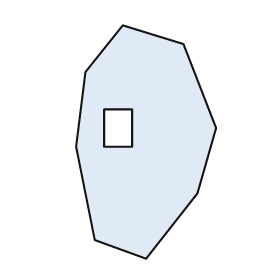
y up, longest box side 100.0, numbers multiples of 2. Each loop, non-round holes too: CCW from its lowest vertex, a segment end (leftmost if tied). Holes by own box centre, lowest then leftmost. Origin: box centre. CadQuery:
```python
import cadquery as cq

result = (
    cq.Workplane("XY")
    .moveTo(0.0, -50.0)
    .lineTo(22.0, -22.0)
    .lineTo(30.0, 6.0)
    .lineTo(16.0, 42.0)
    .lineTo(-10.0, 50.0)
    .lineTo(-26.0, 30.0)
    .lineTo(-30.0, -2.0)
    .lineTo(-22.0, -42.0)
    .close()
    .moveTo(-18.0, -2.0)
    .lineTo(-6.0, -2.0)
    .lineTo(-6.0, 14.0)
    .lineTo(-18.0, 14.0)
    .close()
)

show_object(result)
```